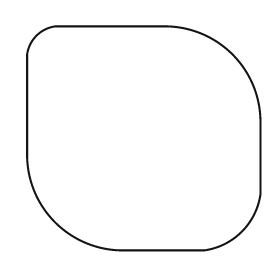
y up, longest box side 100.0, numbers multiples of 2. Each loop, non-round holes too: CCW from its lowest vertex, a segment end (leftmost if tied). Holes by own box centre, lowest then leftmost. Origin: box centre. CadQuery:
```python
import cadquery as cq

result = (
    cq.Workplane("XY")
    .moveTo(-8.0, -48.0)
    .lineTo(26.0, -48.0)
    .threePointArc((42.0, -40.0), (50.0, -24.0))
    .lineTo(50.0, 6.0)
    .threePointArc((38.0, 36.0), (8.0, 48.0))
    .lineTo(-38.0, 48.0)
    .threePointArc((-46.0, 44.0), (-50.0, 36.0))
    .lineTo(-50.0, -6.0)
    .threePointArc((-38.0, -36.0), (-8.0, -48.0))
    .close()
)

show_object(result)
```